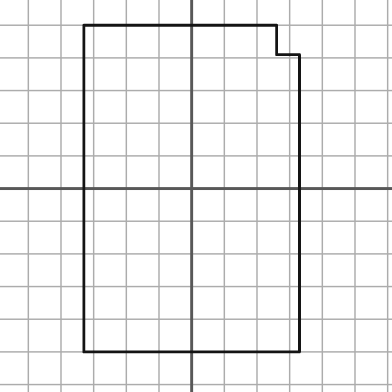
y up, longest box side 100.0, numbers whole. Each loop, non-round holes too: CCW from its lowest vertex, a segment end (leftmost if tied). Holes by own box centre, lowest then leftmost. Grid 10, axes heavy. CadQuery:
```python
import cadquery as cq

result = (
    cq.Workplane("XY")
    .moveTo(-33.0, -50.0)
    .lineTo(33.0, -50.0)
    .lineTo(33.0, 41.0)
    .lineTo(26.0, 41.0)
    .lineTo(26.0, 50.0)
    .lineTo(-33.0, 50.0)
    .close()
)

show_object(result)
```